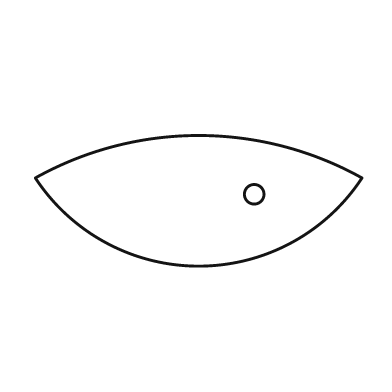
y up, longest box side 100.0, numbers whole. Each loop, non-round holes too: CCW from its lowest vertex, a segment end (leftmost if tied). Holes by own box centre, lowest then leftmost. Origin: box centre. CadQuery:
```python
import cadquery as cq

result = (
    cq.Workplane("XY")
    .moveTo(-50.0, 7.0)
    .threePointArc((0.0, -20.0), (50.0, 7.0))
    .threePointArc((0.0, 20.0), (-50.0, 7.0))
    .close()
    .moveTo(17.0, 2.0)
    .circle(3.0)
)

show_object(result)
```